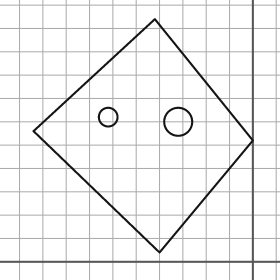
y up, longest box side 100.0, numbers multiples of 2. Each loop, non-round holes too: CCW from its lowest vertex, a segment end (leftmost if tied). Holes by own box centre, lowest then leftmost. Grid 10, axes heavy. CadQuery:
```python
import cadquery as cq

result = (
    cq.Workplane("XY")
    .moveTo(-40.0, 4.0)
    .lineTo(0.0, 52.0)
    .lineTo(-42.0, 104.0)
    .lineTo(-94.0, 56.0)
    .close()
    .moveTo(-32.0, 60.0)
    .circle(6.0)
    .moveTo(-62.0, 62.0)
    .circle(4.0)
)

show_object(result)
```